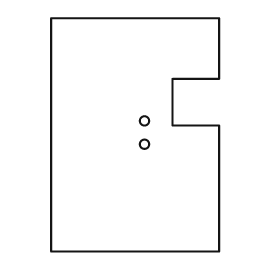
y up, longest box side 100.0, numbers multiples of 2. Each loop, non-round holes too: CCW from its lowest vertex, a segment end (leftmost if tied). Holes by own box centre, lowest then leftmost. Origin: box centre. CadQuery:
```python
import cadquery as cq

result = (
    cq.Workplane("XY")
    .moveTo(-36.0, -50.0)
    .lineTo(36.0, -50.0)
    .lineTo(36.0, 4.0)
    .lineTo(16.0, 4.0)
    .lineTo(16.0, 24.0)
    .lineTo(36.0, 24.0)
    .lineTo(36.0, 50.0)
    .lineTo(-36.0, 50.0)
    .close()
    .moveTo(4.0, -4.0)
    .circle(2.0)
    .moveTo(4.0, 6.0)
    .circle(2.0)
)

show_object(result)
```